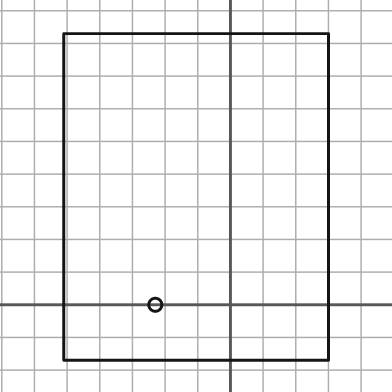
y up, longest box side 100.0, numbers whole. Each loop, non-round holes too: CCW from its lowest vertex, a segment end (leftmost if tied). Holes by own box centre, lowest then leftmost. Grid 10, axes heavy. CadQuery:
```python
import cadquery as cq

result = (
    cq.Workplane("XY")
    .moveTo(-51.0, -17.0)
    .lineTo(30.0, -17.0)
    .lineTo(30.0, 83.0)
    .lineTo(-51.0, 83.0)
    .close()
    .moveTo(-23.0, 0.0)
    .circle(2.0)
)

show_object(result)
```